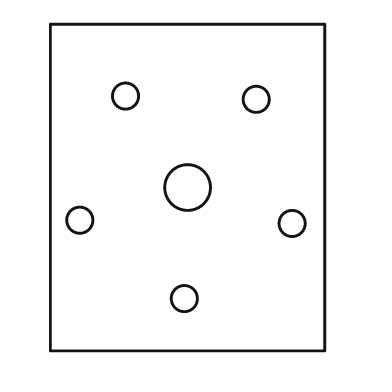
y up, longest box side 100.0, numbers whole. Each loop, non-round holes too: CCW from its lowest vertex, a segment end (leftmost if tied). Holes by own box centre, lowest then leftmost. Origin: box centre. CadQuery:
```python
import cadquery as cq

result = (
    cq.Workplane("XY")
    .moveTo(-42.0, -50.0)
    .lineTo(42.0, -50.0)
    .lineTo(42.0, 50.0)
    .lineTo(-42.0, 50.0)
    .close()
    .moveTo(-1.0, -34.0)
    .circle(4.0)
    .moveTo(32.0, -11.0)
    .circle(4.0)
    .moveTo(-33.0, -10.0)
    .circle(4.0)
    .moveTo(0.0, 0.0)
    .circle(7.0)
    .moveTo(21.0, 27.0)
    .circle(4.0)
    .moveTo(-19.0, 28.0)
    .circle(4.0)
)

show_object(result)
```